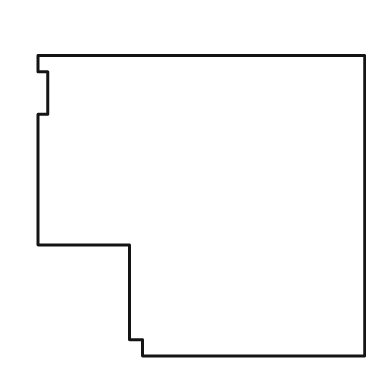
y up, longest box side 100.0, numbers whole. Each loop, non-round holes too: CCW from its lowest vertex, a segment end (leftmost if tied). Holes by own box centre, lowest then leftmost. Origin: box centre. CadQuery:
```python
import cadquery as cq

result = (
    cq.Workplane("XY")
    .moveTo(-18.0, -46.0)
    .lineTo(50.0, -46.0)
    .lineTo(50.0, 46.0)
    .lineTo(-50.0, 46.0)
    .lineTo(-50.0, 41.0)
    .lineTo(-47.0, 41.0)
    .lineTo(-47.0, 28.0)
    .lineTo(-50.0, 28.0)
    .lineTo(-50.0, -12.0)
    .lineTo(-22.0, -12.0)
    .lineTo(-22.0, -41.0)
    .lineTo(-18.0, -41.0)
    .close()
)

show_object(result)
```